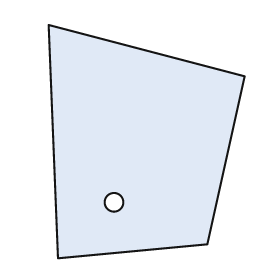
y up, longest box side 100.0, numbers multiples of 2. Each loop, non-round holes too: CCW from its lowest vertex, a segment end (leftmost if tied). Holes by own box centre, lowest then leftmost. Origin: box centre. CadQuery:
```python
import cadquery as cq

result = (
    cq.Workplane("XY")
    .moveTo(-38.0, -50.0)
    .lineTo(26.0, -44.0)
    .lineTo(42.0, 28.0)
    .lineTo(-42.0, 50.0)
    .close()
    .moveTo(-14.0, -26.0)
    .circle(4.0)
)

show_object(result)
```